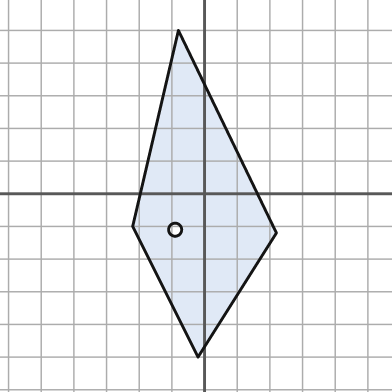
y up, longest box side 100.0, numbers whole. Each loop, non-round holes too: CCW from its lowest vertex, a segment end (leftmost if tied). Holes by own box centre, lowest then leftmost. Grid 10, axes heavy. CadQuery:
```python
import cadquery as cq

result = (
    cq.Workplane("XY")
    .moveTo(-2.0, -50.0)
    .lineTo(22.0, -12.0)
    .lineTo(-8.0, 50.0)
    .lineTo(-22.0, -10.0)
    .close()
    .moveTo(-9.0, -11.0)
    .circle(2.0)
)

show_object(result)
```